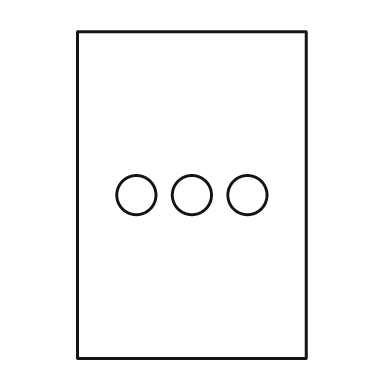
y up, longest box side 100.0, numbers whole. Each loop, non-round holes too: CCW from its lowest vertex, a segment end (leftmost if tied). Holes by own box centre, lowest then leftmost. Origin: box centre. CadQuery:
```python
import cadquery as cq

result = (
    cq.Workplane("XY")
    .moveTo(-35.0, -50.0)
    .lineTo(35.0, -50.0)
    .lineTo(35.0, 50.0)
    .lineTo(-35.0, 50.0)
    .close()
    .moveTo(-17.0, 0.0)
    .circle(6.0)
    .moveTo(0.0, 0.0)
    .circle(6.0)
    .moveTo(17.0, 0.0)
    .circle(6.0)
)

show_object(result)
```